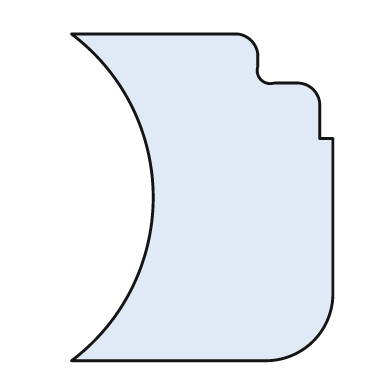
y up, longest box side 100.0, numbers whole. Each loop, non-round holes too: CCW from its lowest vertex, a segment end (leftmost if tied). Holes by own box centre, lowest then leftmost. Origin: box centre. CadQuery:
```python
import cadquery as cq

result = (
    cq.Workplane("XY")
    .moveTo(-40.0, -50.0)
    .lineTo(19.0, -50.0)
    .threePointArc((34.0, -44.0), (40.0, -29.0))
    .lineTo(40.0, 18.0)
    .lineTo(36.0, 18.0)
    .lineTo(36.0, 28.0)
    .threePointArc((34.0, 33.0), (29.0, 35.0))
    .lineTo(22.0, 35.0)
    .threePointArc((18.0, 36.0), (17.0, 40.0))
    .lineTo(17.0, 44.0)
    .threePointArc((15.0, 48.0), (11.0, 50.0))
    .lineTo(-40.0, 50.0)
    .threePointArc((-15.0, 0.0), (-40.0, -50.0))
    .close()
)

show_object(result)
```